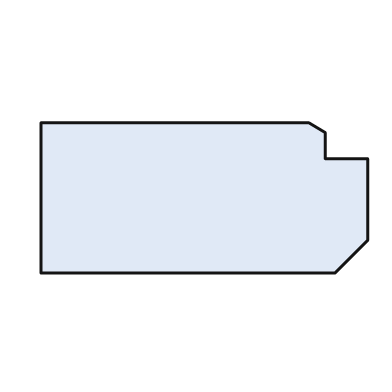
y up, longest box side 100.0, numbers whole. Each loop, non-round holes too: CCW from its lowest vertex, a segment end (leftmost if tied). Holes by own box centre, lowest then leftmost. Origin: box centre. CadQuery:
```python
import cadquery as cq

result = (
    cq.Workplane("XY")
    .moveTo(-50.0, -23.0)
    .lineTo(40.0, -23.0)
    .lineTo(50.0, -13.0)
    .lineTo(50.0, 12.0)
    .lineTo(37.0, 12.0)
    .lineTo(37.0, 20.0)
    .lineTo(32.0, 23.0)
    .lineTo(-50.0, 23.0)
    .close()
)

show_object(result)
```